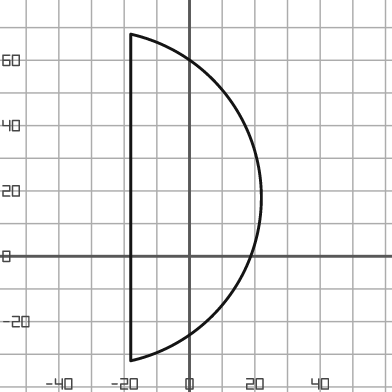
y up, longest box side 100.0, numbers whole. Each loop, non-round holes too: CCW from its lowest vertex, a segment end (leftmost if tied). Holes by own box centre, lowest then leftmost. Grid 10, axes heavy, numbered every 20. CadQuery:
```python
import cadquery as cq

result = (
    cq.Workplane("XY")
    .moveTo(-18.0, -32.0)
    .threePointArc((22.0, 18.0), (-18.0, 68.0))
    .close()
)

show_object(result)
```